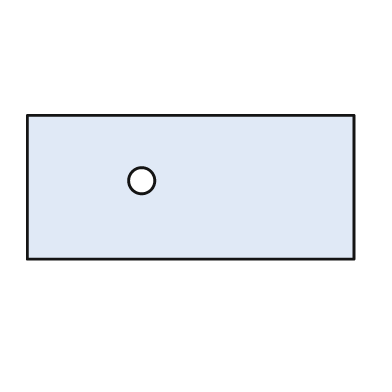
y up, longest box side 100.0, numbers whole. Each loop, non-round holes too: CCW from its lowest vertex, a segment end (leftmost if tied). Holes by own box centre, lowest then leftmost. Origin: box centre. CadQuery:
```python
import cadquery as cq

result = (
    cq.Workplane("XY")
    .moveTo(-50.0, -22.0)
    .lineTo(50.0, -22.0)
    .lineTo(50.0, 22.0)
    .lineTo(-50.0, 22.0)
    .close()
    .moveTo(-15.0, 2.0)
    .circle(4.0)
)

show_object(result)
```